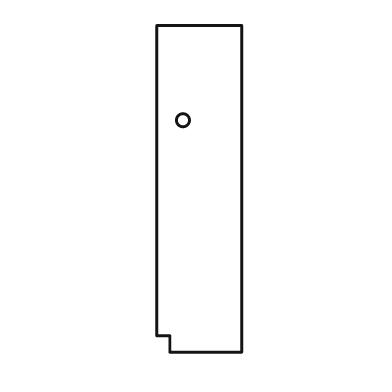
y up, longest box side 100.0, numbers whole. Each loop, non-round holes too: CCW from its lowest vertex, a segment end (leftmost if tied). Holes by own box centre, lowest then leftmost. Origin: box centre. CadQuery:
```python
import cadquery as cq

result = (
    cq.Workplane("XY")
    .moveTo(-9.0, -50.0)
    .lineTo(13.0, -50.0)
    .lineTo(13.0, 50.0)
    .lineTo(-13.0, 50.0)
    .lineTo(-13.0, -45.0)
    .lineTo(-9.0, -45.0)
    .close()
    .moveTo(-5.0, 21.0)
    .circle(2.0)
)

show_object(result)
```